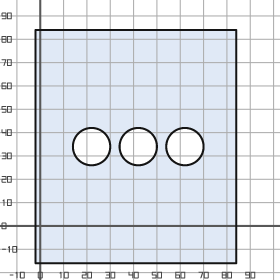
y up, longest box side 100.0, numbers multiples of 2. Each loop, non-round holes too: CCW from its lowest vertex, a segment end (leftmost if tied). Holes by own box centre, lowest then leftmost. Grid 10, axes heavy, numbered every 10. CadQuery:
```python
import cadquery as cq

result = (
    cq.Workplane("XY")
    .moveTo(-2.0, -16.0)
    .lineTo(84.0, -16.0)
    .lineTo(84.0, 84.0)
    .lineTo(-2.0, 84.0)
    .close()
    .moveTo(22.0, 34.0)
    .circle(8.0)
    .moveTo(42.0, 34.0)
    .circle(8.0)
    .moveTo(62.0, 34.0)
    .circle(8.0)
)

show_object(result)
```